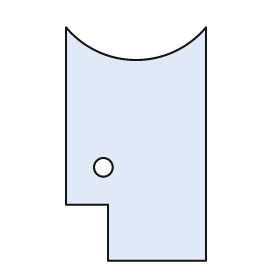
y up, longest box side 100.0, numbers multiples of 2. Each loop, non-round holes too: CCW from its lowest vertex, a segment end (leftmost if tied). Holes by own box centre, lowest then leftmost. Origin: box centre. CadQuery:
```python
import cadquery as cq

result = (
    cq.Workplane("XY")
    .moveTo(-12.0, -50.0)
    .lineTo(30.0, -50.0)
    .lineTo(30.0, 50.0)
    .threePointArc((0.0, 36.0), (-30.0, 50.0))
    .lineTo(-30.0, -26.0)
    .lineTo(-12.0, -26.0)
    .close()
    .moveTo(-14.0, -10.0)
    .circle(4.0)
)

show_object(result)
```